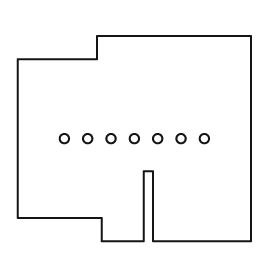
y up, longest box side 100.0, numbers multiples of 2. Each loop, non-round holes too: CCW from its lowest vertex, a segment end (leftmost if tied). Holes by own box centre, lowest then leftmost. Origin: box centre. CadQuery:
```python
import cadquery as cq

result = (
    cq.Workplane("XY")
    .moveTo(-14.0, -44.0)
    .lineTo(4.0, -44.0)
    .lineTo(4.0, -14.0)
    .lineTo(8.0, -14.0)
    .lineTo(8.0, -44.0)
    .lineTo(50.0, -44.0)
    .lineTo(50.0, 44.0)
    .lineTo(-16.0, 44.0)
    .lineTo(-16.0, 34.0)
    .lineTo(-50.0, 34.0)
    .lineTo(-50.0, -34.0)
    .lineTo(-14.0, -34.0)
    .close()
    .moveTo(-30.0, 0.0)
    .circle(2.0)
    .moveTo(-20.0, 0.0)
    .circle(2.0)
    .moveTo(-10.0, 0.0)
    .circle(2.0)
    .moveTo(0.0, 0.0)
    .circle(2.0)
    .moveTo(10.0, 0.0)
    .circle(2.0)
    .moveTo(20.0, 0.0)
    .circle(2.0)
    .moveTo(30.0, 0.0)
    .circle(2.0)
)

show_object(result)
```